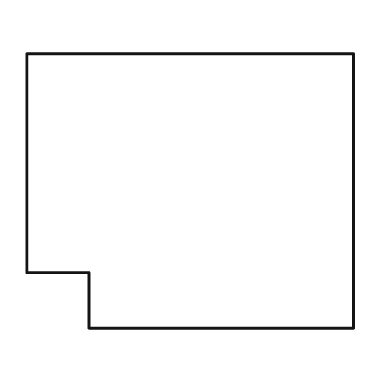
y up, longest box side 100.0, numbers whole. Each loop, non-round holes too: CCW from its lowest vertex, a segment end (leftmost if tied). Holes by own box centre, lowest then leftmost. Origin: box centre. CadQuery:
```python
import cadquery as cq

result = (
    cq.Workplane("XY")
    .moveTo(-31.0, -42.0)
    .lineTo(50.0, -42.0)
    .lineTo(50.0, 42.0)
    .lineTo(-50.0, 42.0)
    .lineTo(-50.0, -25.0)
    .lineTo(-31.0, -25.0)
    .close()
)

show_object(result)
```